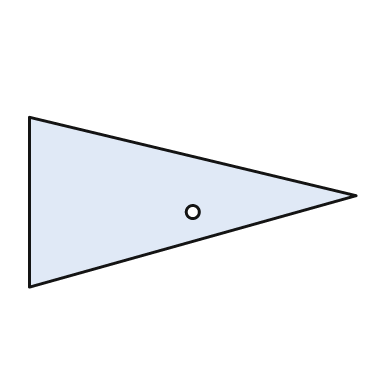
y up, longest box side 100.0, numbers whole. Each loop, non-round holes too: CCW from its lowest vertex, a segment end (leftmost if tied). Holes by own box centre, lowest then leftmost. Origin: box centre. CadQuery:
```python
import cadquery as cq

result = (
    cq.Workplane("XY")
    .moveTo(-50.0, -26.0)
    .lineTo(50.0, 2.0)
    .lineTo(-50.0, 26.0)
    .close()
    .moveTo(0.0, -3.0)
    .circle(2.0)
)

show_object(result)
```